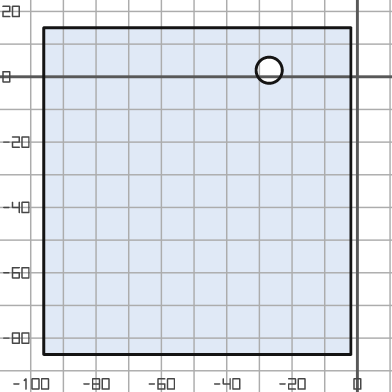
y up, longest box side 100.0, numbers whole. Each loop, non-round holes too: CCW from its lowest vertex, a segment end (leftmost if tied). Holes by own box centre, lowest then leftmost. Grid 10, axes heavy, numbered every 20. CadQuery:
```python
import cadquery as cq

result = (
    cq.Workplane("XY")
    .moveTo(-96.0, -85.0)
    .lineTo(-2.0, -85.0)
    .lineTo(-2.0, 15.0)
    .lineTo(-96.0, 15.0)
    .close()
    .moveTo(-27.0, 2.0)
    .circle(4.0)
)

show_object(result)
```